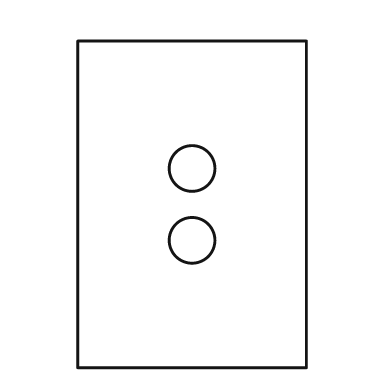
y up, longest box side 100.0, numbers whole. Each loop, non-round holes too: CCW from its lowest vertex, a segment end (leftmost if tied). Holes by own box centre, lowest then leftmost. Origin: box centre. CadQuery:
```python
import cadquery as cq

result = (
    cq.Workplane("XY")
    .moveTo(-35.0, -50.0)
    .lineTo(35.0, -50.0)
    .lineTo(35.0, 50.0)
    .lineTo(-35.0, 50.0)
    .close()
    .moveTo(0.0, -11.0)
    .circle(7.0)
    .moveTo(0.0, 11.0)
    .circle(7.0)
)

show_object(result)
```